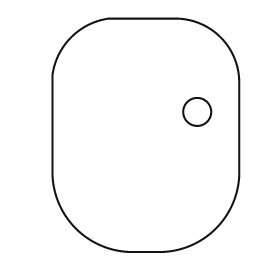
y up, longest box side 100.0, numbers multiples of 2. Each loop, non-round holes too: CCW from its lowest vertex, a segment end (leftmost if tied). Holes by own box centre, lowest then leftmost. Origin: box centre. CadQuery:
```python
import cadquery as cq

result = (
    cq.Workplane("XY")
    .moveTo(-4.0, -50.0)
    .lineTo(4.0, -50.0)
    .threePointArc((30.0, -40.0), (40.0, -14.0))
    .lineTo(40.0, 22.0)
    .threePointArc((32.0, 42.0), (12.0, 50.0))
    .lineTo(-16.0, 50.0)
    .threePointArc((-32.0, 42.0), (-40.0, 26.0))
    .lineTo(-40.0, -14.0)
    .threePointArc((-30.0, -40.0), (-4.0, -50.0))
    .close()
    .moveTo(22.0, 10.0)
    .circle(6.0)
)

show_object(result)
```